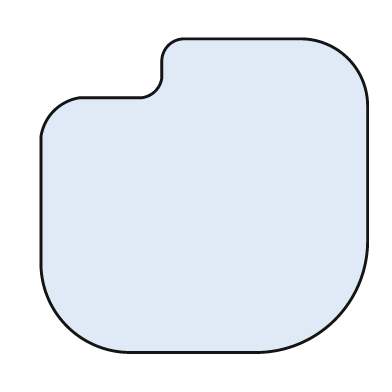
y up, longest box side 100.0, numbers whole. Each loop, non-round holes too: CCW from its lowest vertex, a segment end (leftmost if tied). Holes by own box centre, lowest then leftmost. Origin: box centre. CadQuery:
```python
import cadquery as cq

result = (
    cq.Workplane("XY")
    .moveTo(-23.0, -48.0)
    .lineTo(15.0, -48.0)
    .threePointArc((40.0, -38.0), (50.0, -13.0))
    .lineTo(50.0, 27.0)
    .threePointArc((44.0, 42.0), (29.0, 48.0))
    .lineTo(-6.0, 48.0)
    .threePointArc((-11.0, 46.0), (-13.0, 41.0))
    .lineTo(-13.0, 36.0)
    .threePointArc((-15.0, 32.0), (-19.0, 30.0))
    .lineTo(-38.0, 30.0)
    .threePointArc((-46.0, 26.0), (-50.0, 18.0))
    .lineTo(-50.0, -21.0)
    .threePointArc((-42.0, -40.0), (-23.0, -48.0))
    .close()
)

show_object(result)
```